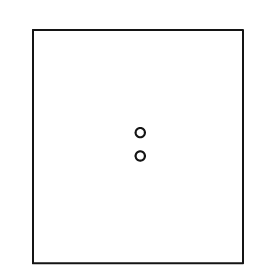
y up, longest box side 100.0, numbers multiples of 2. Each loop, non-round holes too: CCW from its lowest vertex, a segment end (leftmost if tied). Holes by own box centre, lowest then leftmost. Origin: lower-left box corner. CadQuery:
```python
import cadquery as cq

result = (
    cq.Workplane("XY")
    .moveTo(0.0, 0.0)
    .lineTo(90.0, 0.0)
    .lineTo(90.0, 100.0)
    .lineTo(0.0, 100.0)
    .close()
    .moveTo(46.0, 46.0)
    .circle(2.0)
    .moveTo(46.0, 56.0)
    .circle(2.0)
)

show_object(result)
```